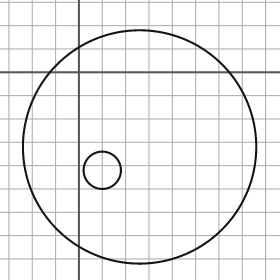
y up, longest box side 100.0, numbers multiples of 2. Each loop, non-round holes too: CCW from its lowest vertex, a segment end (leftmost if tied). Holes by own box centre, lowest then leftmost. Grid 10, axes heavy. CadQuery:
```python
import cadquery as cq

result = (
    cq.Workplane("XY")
    .moveTo(26.0, -32.0)
    .circle(50.0)
    .moveTo(10.0, -42.0)
    .circle(8.0)
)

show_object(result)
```